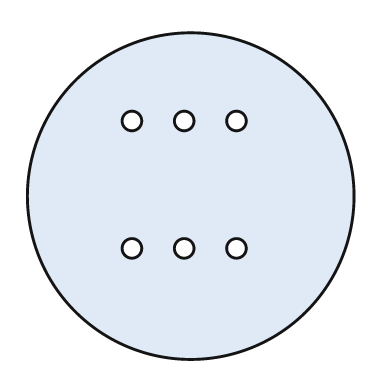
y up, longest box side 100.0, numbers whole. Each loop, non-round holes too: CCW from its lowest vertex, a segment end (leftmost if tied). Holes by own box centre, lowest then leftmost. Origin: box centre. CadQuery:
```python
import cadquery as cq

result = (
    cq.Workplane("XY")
    .moveTo(0.0, 0.0)
    .circle(50.0)
    .moveTo(-18.0, -16.0)
    .circle(3.0)
    .moveTo(-2.0, -16.0)
    .circle(3.0)
    .moveTo(14.0, -16.0)
    .circle(3.0)
    .moveTo(-18.0, 23.0)
    .circle(3.0)
    .moveTo(-2.0, 23.0)
    .circle(3.0)
    .moveTo(14.0, 23.0)
    .circle(3.0)
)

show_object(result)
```